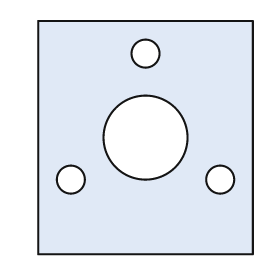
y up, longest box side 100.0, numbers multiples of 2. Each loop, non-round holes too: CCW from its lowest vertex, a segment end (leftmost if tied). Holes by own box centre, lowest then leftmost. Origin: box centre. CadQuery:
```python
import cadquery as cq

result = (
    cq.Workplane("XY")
    .moveTo(-46.0, -50.0)
    .lineTo(46.0, -50.0)
    .lineTo(46.0, 50.0)
    .lineTo(-46.0, 50.0)
    .close()
    .moveTo(-32.0, -18.0)
    .circle(6.0)
    .moveTo(32.0, -18.0)
    .circle(6.0)
    .moveTo(0.0, 0.0)
    .circle(18.0)
    .moveTo(0.0, 36.0)
    .circle(6.0)
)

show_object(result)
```